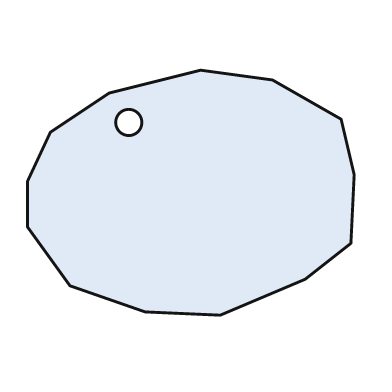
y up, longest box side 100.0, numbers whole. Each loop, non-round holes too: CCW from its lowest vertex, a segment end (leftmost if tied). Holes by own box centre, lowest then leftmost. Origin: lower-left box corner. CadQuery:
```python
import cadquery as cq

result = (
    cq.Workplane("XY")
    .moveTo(59.0, 0.0)
    .lineTo(85.0, 11.0)
    .lineTo(99.0, 22.0)
    .lineTo(100.0, 43.0)
    .lineTo(96.0, 60.0)
    .lineTo(75.0, 72.0)
    .lineTo(53.0, 75.0)
    .lineTo(25.0, 68.0)
    .lineTo(7.0, 56.0)
    .lineTo(0.0, 41.0)
    .lineTo(0.0, 27.0)
    .lineTo(13.0, 9.0)
    .lineTo(36.0, 1.0)
    .close()
    .moveTo(31.0, 59.0)
    .circle(4.0)
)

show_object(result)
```